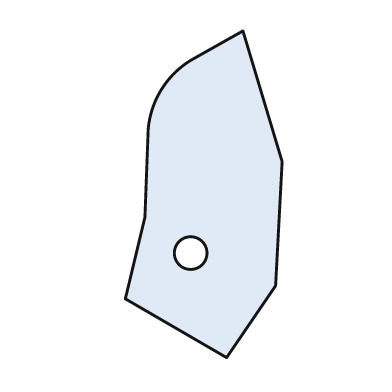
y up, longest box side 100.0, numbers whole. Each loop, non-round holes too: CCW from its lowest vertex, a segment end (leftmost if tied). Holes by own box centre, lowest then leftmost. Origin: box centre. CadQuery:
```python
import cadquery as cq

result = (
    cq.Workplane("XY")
    .moveTo(7.0, -50.0)
    .lineTo(22.0, -28.0)
    .lineTo(24.0, 10.0)
    .lineTo(12.0, 50.0)
    .lineTo(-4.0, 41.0)
    .threePointArc((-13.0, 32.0), (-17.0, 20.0))
    .lineTo(-18.0, -7.0)
    .lineTo(-24.0, -32.0)
    .close()
    .moveTo(-4.0, -18.0)
    .circle(5.0)
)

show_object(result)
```